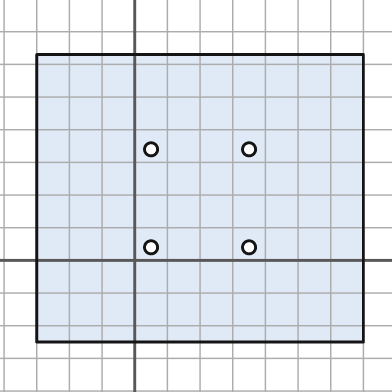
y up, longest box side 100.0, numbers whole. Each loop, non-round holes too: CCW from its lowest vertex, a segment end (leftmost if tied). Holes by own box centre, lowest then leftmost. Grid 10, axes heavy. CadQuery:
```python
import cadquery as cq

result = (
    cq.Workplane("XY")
    .moveTo(-30.0, -25.0)
    .lineTo(70.0, -25.0)
    .lineTo(70.0, 63.0)
    .lineTo(-30.0, 63.0)
    .close()
    .moveTo(5.0, 4.0)
    .circle(2.0)
    .moveTo(35.0, 4.0)
    .circle(2.0)
    .moveTo(5.0, 34.0)
    .circle(2.0)
    .moveTo(35.0, 34.0)
    .circle(2.0)
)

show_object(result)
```